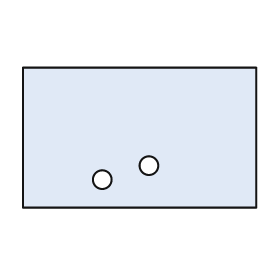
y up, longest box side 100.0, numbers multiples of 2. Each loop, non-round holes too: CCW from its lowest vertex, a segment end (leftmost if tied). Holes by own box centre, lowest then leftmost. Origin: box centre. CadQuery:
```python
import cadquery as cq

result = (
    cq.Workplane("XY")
    .moveTo(-50.0, -30.0)
    .lineTo(50.0, -30.0)
    .lineTo(50.0, 30.0)
    .lineTo(-50.0, 30.0)
    .close()
    .moveTo(-16.0, -18.0)
    .circle(4.0)
    .moveTo(4.0, -12.0)
    .circle(4.0)
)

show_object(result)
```